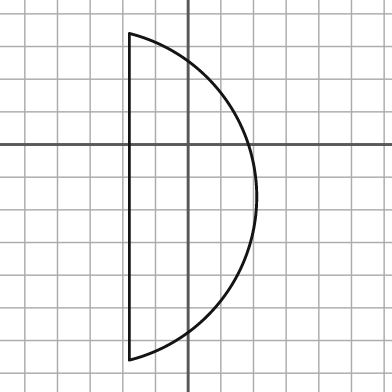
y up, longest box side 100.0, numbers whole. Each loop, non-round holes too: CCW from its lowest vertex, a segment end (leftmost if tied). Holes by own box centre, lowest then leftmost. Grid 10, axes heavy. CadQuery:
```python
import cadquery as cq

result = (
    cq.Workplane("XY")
    .moveTo(-18.0, -66.0)
    .threePointArc((21.0, -16.0), (-18.0, 34.0))
    .close()
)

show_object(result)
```